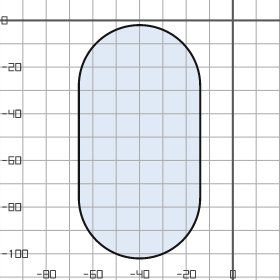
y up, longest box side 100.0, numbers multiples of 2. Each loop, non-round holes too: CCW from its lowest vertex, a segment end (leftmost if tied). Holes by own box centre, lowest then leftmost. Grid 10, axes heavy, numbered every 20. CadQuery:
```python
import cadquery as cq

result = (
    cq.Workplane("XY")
    .moveTo(-66.0, -76.0)
    .threePointArc((-40.0, -102.0), (-14.0, -76.0))
    .lineTo(-14.0, -28.0)
    .threePointArc((-40.0, -2.0), (-66.0, -28.0))
    .close()
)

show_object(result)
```